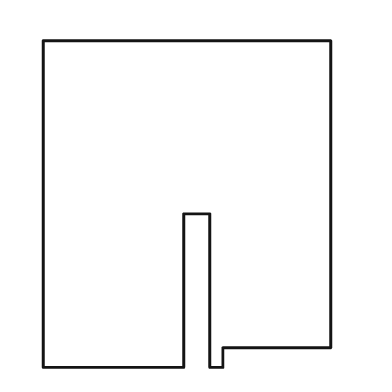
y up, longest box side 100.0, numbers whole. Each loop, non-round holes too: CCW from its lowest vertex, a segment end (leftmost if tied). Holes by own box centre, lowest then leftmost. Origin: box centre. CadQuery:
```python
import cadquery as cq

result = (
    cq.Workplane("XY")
    .moveTo(-44.0, -50.0)
    .lineTo(-1.0, -50.0)
    .lineTo(-1.0, -3.0)
    .lineTo(7.0, -3.0)
    .lineTo(7.0, -50.0)
    .lineTo(11.0, -50.0)
    .lineTo(11.0, -44.0)
    .lineTo(44.0, -44.0)
    .lineTo(44.0, 50.0)
    .lineTo(-44.0, 50.0)
    .close()
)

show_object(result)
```